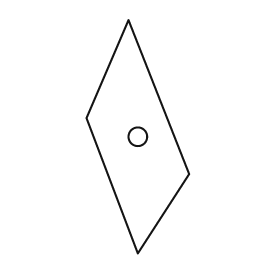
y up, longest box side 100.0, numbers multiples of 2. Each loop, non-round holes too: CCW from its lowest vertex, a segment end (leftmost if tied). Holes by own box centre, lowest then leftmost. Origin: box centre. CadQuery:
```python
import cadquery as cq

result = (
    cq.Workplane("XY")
    .moveTo(0.0, -50.0)
    .lineTo(22.0, -16.0)
    .lineTo(-4.0, 50.0)
    .lineTo(-22.0, 8.0)
    .close()
    .moveTo(0.0, 0.0)
    .circle(4.0)
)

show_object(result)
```